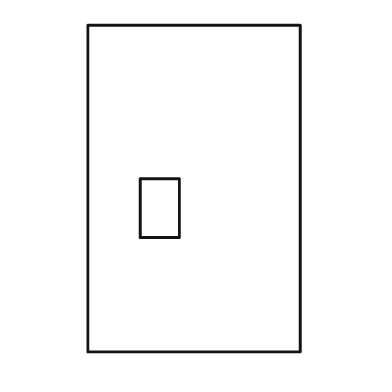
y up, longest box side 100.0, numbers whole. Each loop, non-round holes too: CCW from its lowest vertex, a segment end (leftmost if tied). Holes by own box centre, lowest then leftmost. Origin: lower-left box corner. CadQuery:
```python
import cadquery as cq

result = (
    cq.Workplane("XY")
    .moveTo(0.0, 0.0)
    .lineTo(65.0, 0.0)
    .lineTo(65.0, 100.0)
    .lineTo(0.0, 100.0)
    .close()
    .moveTo(16.0, 35.0)
    .lineTo(28.0, 35.0)
    .lineTo(28.0, 53.0)
    .lineTo(16.0, 53.0)
    .close()
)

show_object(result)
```